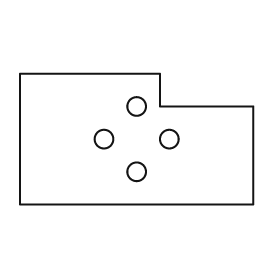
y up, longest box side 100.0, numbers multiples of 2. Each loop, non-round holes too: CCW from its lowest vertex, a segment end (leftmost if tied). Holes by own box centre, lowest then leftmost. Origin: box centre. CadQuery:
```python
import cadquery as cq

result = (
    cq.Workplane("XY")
    .moveTo(-50.0, -28.0)
    .lineTo(50.0, -28.0)
    .lineTo(50.0, 14.0)
    .lineTo(10.0, 14.0)
    .lineTo(10.0, 28.0)
    .lineTo(-50.0, 28.0)
    .close()
    .moveTo(0.0, -14.0)
    .circle(4.0)
    .moveTo(-14.0, 0.0)
    .circle(4.0)
    .moveTo(14.0, 0.0)
    .circle(4.0)
    .moveTo(0.0, 14.0)
    .circle(4.0)
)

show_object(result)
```